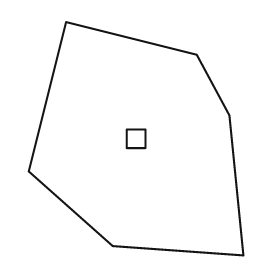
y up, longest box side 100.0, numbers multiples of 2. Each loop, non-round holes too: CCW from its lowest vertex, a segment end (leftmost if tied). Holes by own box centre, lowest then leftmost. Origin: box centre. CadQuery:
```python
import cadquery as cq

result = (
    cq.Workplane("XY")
    .moveTo(46.0, -50.0)
    .lineTo(40.0, 10.0)
    .lineTo(26.0, 36.0)
    .lineTo(-30.0, 50.0)
    .lineTo(-46.0, -14.0)
    .lineTo(-10.0, -46.0)
    .close()
    .moveTo(-4.0, -4.0)
    .lineTo(4.0, -4.0)
    .lineTo(4.0, 4.0)
    .lineTo(-4.0, 4.0)
    .close()
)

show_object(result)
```